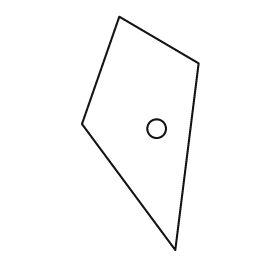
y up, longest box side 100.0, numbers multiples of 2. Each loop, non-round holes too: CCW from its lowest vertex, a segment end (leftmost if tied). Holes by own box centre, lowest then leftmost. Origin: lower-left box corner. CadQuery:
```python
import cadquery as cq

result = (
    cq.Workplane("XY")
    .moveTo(40.0, 0.0)
    .lineTo(50.0, 80.0)
    .lineTo(16.0, 100.0)
    .lineTo(0.0, 54.0)
    .close()
    .moveTo(32.0, 52.0)
    .circle(4.0)
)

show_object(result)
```